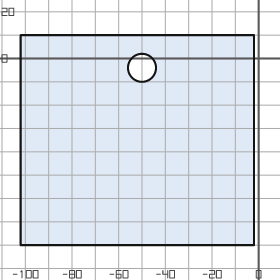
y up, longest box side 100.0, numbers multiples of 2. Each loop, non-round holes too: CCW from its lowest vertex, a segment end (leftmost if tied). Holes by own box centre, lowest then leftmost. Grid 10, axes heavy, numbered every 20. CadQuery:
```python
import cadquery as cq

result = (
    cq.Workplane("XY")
    .moveTo(-102.0, -80.0)
    .lineTo(-2.0, -80.0)
    .lineTo(-2.0, 10.0)
    .lineTo(-102.0, 10.0)
    .close()
    .moveTo(-50.0, -4.0)
    .circle(6.0)
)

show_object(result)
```